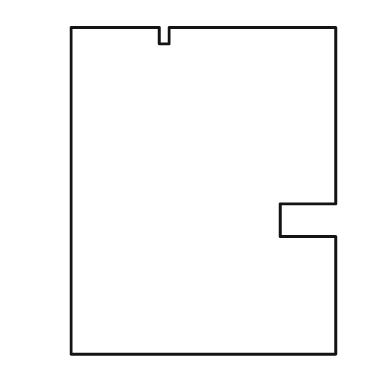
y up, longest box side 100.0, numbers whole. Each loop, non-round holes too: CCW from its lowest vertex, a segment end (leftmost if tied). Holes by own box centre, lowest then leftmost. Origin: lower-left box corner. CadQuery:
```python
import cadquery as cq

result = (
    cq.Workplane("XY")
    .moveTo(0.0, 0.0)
    .lineTo(81.0, 0.0)
    .lineTo(81.0, 36.0)
    .lineTo(64.0, 36.0)
    .lineTo(64.0, 46.0)
    .lineTo(81.0, 46.0)
    .lineTo(81.0, 100.0)
    .lineTo(30.0, 100.0)
    .lineTo(30.0, 95.0)
    .lineTo(27.0, 95.0)
    .lineTo(27.0, 100.0)
    .lineTo(0.0, 100.0)
    .close()
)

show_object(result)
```